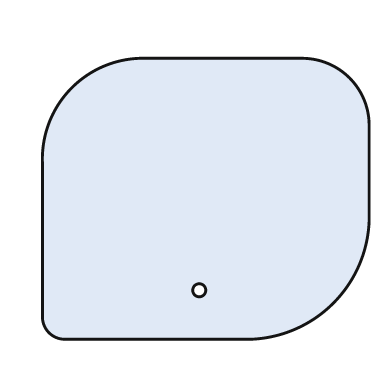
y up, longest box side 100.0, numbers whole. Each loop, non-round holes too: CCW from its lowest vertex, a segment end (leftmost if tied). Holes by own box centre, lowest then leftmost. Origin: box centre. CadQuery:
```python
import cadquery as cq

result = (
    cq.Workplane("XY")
    .moveTo(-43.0, -43.0)
    .lineTo(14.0, -43.0)
    .threePointArc((39.0, -32.0), (50.0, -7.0))
    .lineTo(50.0, 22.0)
    .threePointArc((44.0, 37.0), (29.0, 43.0))
    .lineTo(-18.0, 43.0)
    .threePointArc((-41.0, 34.0), (-50.0, 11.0))
    .lineTo(-50.0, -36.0)
    .threePointArc((-48.0, -41.0), (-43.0, -43.0))
    .close()
    .moveTo(-2.0, -28.0)
    .circle(2.0)
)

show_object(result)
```